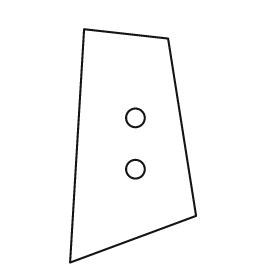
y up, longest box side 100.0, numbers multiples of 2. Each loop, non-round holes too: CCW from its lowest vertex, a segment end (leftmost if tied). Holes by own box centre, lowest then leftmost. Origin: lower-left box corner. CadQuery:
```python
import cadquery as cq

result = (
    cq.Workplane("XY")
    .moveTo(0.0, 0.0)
    .lineTo(54.0, 20.0)
    .lineTo(42.0, 96.0)
    .lineTo(6.0, 100.0)
    .close()
    .moveTo(28.0, 40.0)
    .circle(4.0)
    .moveTo(28.0, 62.0)
    .circle(4.0)
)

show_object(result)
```